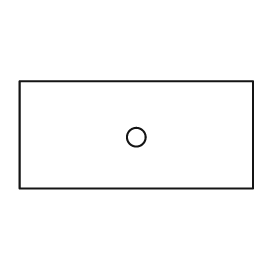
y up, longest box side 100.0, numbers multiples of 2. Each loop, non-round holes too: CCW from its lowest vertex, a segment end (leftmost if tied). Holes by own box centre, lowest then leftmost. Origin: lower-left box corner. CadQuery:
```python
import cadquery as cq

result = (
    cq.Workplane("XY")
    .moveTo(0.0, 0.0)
    .lineTo(100.0, 0.0)
    .lineTo(100.0, 46.0)
    .lineTo(0.0, 46.0)
    .close()
    .moveTo(50.0, 22.0)
    .circle(4.0)
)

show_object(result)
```